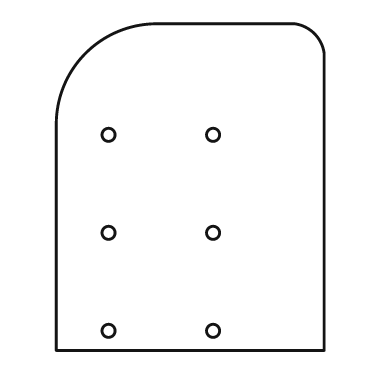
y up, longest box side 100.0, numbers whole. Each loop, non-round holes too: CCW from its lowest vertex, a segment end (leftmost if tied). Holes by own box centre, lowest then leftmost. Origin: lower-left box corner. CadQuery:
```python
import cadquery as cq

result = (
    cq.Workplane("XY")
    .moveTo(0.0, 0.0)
    .lineTo(82.0, 0.0)
    .lineTo(82.0, 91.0)
    .threePointArc((79.0, 97.0), (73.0, 100.0))
    .lineTo(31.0, 100.0)
    .threePointArc((9.0, 91.0), (0.0, 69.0))
    .close()
    .moveTo(16.0, 6.0)
    .circle(2.0)
    .moveTo(48.0, 6.0)
    .circle(2.0)
    .moveTo(16.0, 36.0)
    .circle(2.0)
    .moveTo(48.0, 36.0)
    .circle(2.0)
    .moveTo(16.0, 66.0)
    .circle(2.0)
    .moveTo(48.0, 66.0)
    .circle(2.0)
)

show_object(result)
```